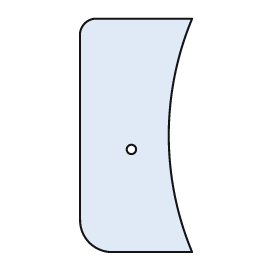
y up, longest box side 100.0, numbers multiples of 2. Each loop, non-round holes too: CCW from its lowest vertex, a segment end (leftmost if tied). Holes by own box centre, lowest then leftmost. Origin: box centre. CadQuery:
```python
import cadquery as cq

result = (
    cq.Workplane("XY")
    .moveTo(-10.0, -50.0)
    .lineTo(24.0, -50.0)
    .threePointArc((14.0, 0.0), (24.0, 50.0))
    .lineTo(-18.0, 50.0)
    .threePointArc((-22.0, 48.0), (-24.0, 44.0))
    .lineTo(-24.0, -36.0)
    .threePointArc((-20.0, -46.0), (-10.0, -50.0))
    .close()
    .moveTo(-2.0, -6.0)
    .circle(2.0)
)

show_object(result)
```